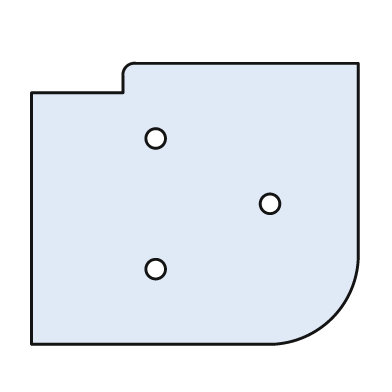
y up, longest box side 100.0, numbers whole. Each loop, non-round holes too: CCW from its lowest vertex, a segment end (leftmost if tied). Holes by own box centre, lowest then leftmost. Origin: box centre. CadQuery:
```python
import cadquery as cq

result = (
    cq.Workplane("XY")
    .moveTo(-50.0, -43.0)
    .lineTo(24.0, -43.0)
    .threePointArc((42.0, -35.0), (50.0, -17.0))
    .lineTo(50.0, 43.0)
    .lineTo(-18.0, 43.0)
    .threePointArc((-21.0, 42.0), (-22.0, 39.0))
    .lineTo(-22.0, 34.0)
    .lineTo(-50.0, 34.0)
    .close()
    .moveTo(-12.0, -20.0)
    .circle(3.0)
    .moveTo(23.0, 0.0)
    .circle(3.0)
    .moveTo(-12.0, 20.0)
    .circle(3.0)
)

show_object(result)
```